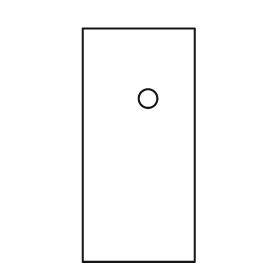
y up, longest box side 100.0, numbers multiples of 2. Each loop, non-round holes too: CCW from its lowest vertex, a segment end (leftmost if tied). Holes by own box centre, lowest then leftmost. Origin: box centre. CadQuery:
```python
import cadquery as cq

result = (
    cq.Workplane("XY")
    .moveTo(-24.0, -50.0)
    .lineTo(24.0, -50.0)
    .lineTo(24.0, 50.0)
    .lineTo(-24.0, 50.0)
    .close()
    .moveTo(4.0, 20.0)
    .circle(4.0)
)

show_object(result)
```